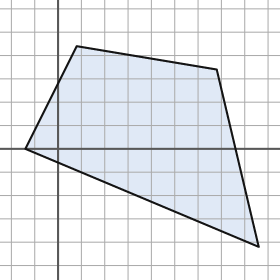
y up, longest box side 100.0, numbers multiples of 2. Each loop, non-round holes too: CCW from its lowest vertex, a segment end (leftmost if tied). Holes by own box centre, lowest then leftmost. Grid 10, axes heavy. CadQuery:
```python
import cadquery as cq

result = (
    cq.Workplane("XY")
    .moveTo(86.0, -42.0)
    .lineTo(68.0, 34.0)
    .lineTo(8.0, 44.0)
    .lineTo(-14.0, 0.0)
    .close()
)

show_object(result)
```